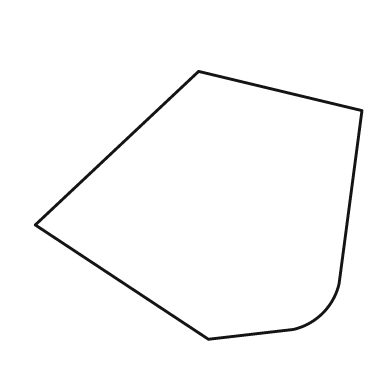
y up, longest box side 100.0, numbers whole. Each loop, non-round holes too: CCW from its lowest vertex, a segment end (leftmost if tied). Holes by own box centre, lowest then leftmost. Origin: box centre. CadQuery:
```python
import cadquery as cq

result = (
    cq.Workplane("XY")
    .moveTo(3.0, -41.0)
    .lineTo(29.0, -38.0)
    .threePointArc((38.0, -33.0), (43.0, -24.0))
    .lineTo(50.0, 29.0)
    .lineTo(0.0, 41.0)
    .lineTo(-50.0, -6.0)
    .close()
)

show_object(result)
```